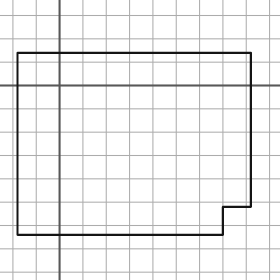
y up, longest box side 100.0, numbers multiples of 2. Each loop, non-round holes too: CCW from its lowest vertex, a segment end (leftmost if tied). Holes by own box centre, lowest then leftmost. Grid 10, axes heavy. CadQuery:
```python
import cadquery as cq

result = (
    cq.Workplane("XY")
    .moveTo(-18.0, -64.0)
    .lineTo(70.0, -64.0)
    .lineTo(70.0, -52.0)
    .lineTo(82.0, -52.0)
    .lineTo(82.0, 14.0)
    .lineTo(-18.0, 14.0)
    .close()
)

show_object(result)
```